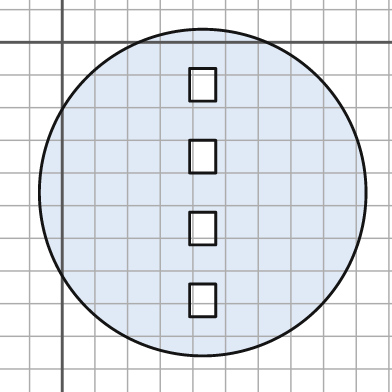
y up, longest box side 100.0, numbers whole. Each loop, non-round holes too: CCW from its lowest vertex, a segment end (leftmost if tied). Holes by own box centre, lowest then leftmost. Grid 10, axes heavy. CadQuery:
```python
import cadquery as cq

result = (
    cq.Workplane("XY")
    .moveTo(43.0, -46.0)
    .circle(50.0)
    .moveTo(39.0, -84.0)
    .lineTo(47.0, -84.0)
    .lineTo(47.0, -74.0)
    .lineTo(39.0, -74.0)
    .close()
    .moveTo(39.0, -62.0)
    .lineTo(47.0, -62.0)
    .lineTo(47.0, -52.0)
    .lineTo(39.0, -52.0)
    .close()
    .moveTo(39.0, -40.0)
    .lineTo(47.0, -40.0)
    .lineTo(47.0, -30.0)
    .lineTo(39.0, -30.0)
    .close()
    .moveTo(39.0, -18.0)
    .lineTo(47.0, -18.0)
    .lineTo(47.0, -8.0)
    .lineTo(39.0, -8.0)
    .close()
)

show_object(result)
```